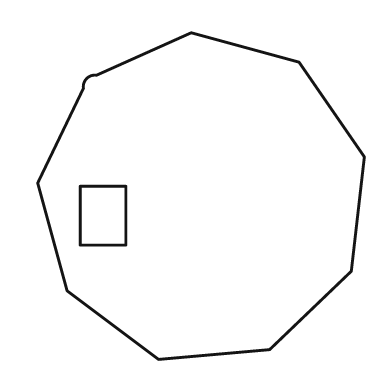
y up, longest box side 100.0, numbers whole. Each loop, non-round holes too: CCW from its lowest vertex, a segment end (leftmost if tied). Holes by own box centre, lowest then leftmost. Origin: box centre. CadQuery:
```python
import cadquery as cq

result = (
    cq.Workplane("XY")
    .moveTo(-13.0, -50.0)
    .lineTo(21.0, -47.0)
    .lineTo(46.0, -23.0)
    .lineTo(50.0, 12.0)
    .lineTo(30.0, 41.0)
    .lineTo(-3.0, 50.0)
    .lineTo(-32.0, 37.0)
    .threePointArc((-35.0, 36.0), (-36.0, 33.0))
    .lineTo(-50.0, 4.0)
    .lineTo(-41.0, -29.0)
    .close()
    .moveTo(-37.0, -15.0)
    .lineTo(-23.0, -15.0)
    .lineTo(-23.0, 3.0)
    .lineTo(-37.0, 3.0)
    .close()
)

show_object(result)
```